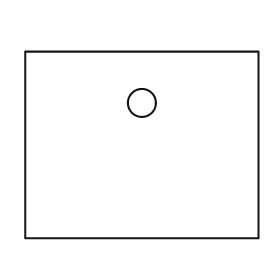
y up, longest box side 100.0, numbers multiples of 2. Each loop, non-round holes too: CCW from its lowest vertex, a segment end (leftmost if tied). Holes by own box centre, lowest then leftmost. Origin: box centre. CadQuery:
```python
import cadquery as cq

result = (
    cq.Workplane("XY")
    .moveTo(-50.0, -40.0)
    .lineTo(50.0, -40.0)
    .lineTo(50.0, 40.0)
    .lineTo(-50.0, 40.0)
    .close()
    .moveTo(0.0, 18.0)
    .circle(6.0)
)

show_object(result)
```